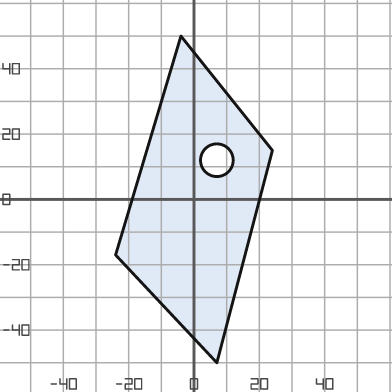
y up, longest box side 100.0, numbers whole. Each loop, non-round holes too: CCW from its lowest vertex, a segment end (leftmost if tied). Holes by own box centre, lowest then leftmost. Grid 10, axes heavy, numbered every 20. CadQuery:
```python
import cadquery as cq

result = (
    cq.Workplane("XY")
    .moveTo(7.0, -50.0)
    .lineTo(24.0, 15.0)
    .lineTo(-4.0, 50.0)
    .lineTo(-24.0, -17.0)
    .close()
    .moveTo(7.0, 12.0)
    .circle(5.0)
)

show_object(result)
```